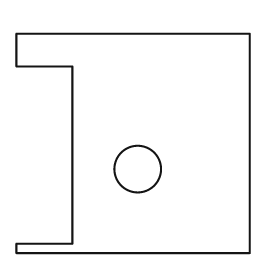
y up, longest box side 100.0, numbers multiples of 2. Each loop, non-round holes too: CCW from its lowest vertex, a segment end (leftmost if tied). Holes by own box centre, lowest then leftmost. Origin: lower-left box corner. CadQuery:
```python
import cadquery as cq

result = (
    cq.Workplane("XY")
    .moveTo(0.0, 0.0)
    .lineTo(100.0, 0.0)
    .lineTo(100.0, 94.0)
    .lineTo(0.0, 94.0)
    .lineTo(0.0, 80.0)
    .lineTo(24.0, 80.0)
    .lineTo(24.0, 4.0)
    .lineTo(0.0, 4.0)
    .close()
    .moveTo(52.0, 36.0)
    .circle(10.0)
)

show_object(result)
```